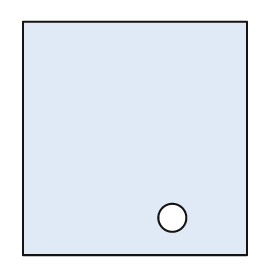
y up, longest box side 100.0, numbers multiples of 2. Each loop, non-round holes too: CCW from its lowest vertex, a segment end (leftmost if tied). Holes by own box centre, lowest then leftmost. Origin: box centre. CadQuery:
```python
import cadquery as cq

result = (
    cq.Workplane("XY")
    .moveTo(-48.0, -50.0)
    .lineTo(48.0, -50.0)
    .lineTo(48.0, 50.0)
    .lineTo(-48.0, 50.0)
    .close()
    .moveTo(16.0, -34.0)
    .circle(6.0)
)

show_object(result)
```